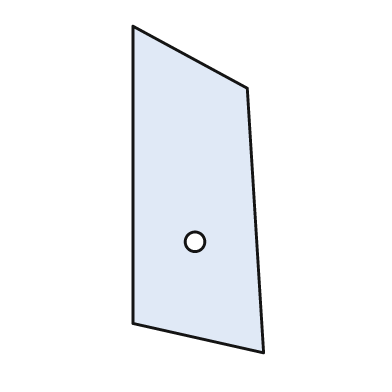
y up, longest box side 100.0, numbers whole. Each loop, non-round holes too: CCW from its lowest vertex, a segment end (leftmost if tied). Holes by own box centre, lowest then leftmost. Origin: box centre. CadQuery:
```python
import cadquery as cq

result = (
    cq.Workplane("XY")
    .moveTo(20.0, -50.0)
    .lineTo(15.0, 31.0)
    .lineTo(-20.0, 50.0)
    .lineTo(-20.0, -41.0)
    .close()
    .moveTo(-1.0, -16.0)
    .circle(3.0)
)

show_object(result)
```